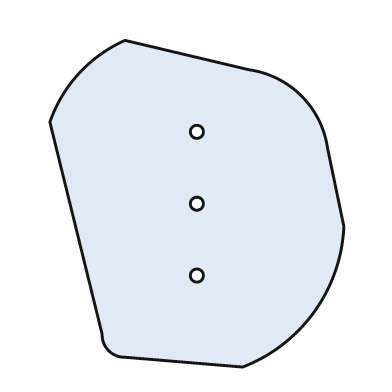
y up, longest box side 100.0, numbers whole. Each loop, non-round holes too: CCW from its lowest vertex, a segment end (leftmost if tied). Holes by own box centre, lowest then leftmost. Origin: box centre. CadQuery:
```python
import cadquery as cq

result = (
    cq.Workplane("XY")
    .moveTo(14.0, -50.0)
    .threePointArc((36.0, -33.0), (45.0, -7.0))
    .lineTo(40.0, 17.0)
    .threePointArc((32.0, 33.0), (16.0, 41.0))
    .lineTo(-22.0, 50.0)
    .threePointArc((-36.0, 40.0), (-45.0, 25.0))
    .lineTo(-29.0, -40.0)
    .threePointArc((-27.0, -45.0), (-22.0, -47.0))
    .close()
    .moveTo(0.0, -22.0)
    .circle(2.0)
    .moveTo(0.0, 0.0)
    .circle(2.0)
    .moveTo(0.0, 22.0)
    .circle(2.0)
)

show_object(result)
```